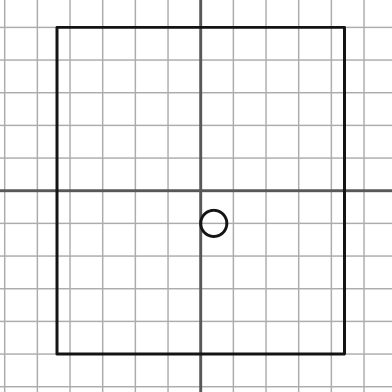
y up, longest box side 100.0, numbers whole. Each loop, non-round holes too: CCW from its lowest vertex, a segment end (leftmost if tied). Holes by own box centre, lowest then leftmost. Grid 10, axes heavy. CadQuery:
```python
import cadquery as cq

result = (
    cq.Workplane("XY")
    .moveTo(-44.0, -50.0)
    .lineTo(44.0, -50.0)
    .lineTo(44.0, 50.0)
    .lineTo(-44.0, 50.0)
    .close()
    .moveTo(4.0, -10.0)
    .circle(4.0)
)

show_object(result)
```